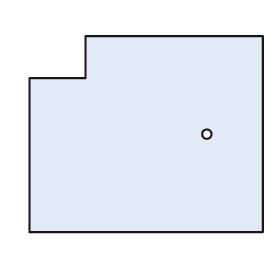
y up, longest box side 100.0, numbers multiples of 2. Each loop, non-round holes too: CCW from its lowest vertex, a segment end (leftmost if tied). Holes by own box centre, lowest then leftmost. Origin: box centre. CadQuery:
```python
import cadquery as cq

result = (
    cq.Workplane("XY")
    .moveTo(-50.0, -42.0)
    .lineTo(50.0, -42.0)
    .lineTo(50.0, 42.0)
    .lineTo(-26.0, 42.0)
    .lineTo(-26.0, 24.0)
    .lineTo(-50.0, 24.0)
    .close()
    .moveTo(26.0, 0.0)
    .circle(2.0)
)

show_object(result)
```